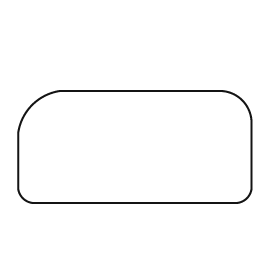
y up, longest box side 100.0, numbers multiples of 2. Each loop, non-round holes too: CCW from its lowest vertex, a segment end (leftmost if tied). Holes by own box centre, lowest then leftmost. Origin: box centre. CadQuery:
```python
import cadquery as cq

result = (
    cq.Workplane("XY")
    .moveTo(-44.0, -24.0)
    .lineTo(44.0, -24.0)
    .threePointArc((48.0, -22.0), (50.0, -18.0))
    .lineTo(50.0, 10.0)
    .threePointArc((46.0, 20.0), (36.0, 24.0))
    .lineTo(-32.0, 24.0)
    .threePointArc((-44.0, 18.0), (-50.0, 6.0))
    .lineTo(-50.0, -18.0)
    .threePointArc((-48.0, -22.0), (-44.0, -24.0))
    .close()
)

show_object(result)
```